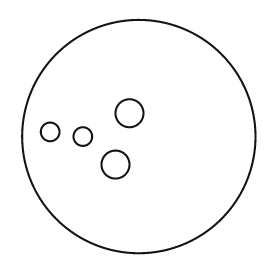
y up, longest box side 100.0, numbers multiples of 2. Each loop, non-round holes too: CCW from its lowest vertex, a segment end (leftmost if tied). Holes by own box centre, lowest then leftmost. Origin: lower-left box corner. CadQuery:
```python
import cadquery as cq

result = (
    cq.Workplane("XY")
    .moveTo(50.0, 50.0)
    .circle(50.0)
    .moveTo(40.0, 38.0)
    .circle(6.0)
    .moveTo(26.0, 50.0)
    .circle(4.0)
    .moveTo(12.0, 52.0)
    .circle(4.0)
    .moveTo(46.0, 60.0)
    .circle(6.0)
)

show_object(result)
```